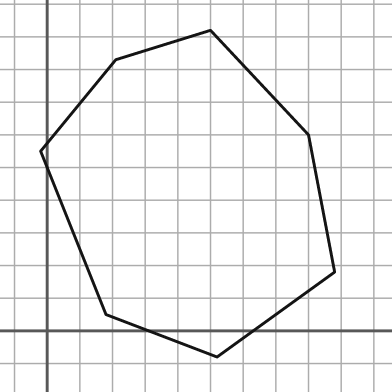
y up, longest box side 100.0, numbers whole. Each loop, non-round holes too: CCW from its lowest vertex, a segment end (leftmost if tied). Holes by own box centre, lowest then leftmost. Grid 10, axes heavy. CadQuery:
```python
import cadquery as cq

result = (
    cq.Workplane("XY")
    .moveTo(52.0, -8.0)
    .lineTo(88.0, 18.0)
    .lineTo(80.0, 60.0)
    .lineTo(50.0, 92.0)
    .lineTo(21.0, 83.0)
    .lineTo(-2.0, 55.0)
    .lineTo(18.0, 5.0)
    .close()
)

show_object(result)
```